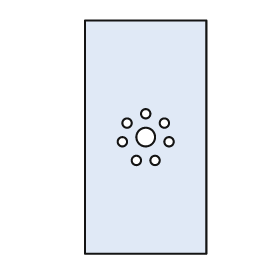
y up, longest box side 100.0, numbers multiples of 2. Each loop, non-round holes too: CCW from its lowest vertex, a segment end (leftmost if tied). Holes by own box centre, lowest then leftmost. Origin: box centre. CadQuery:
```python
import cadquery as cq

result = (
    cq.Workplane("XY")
    .moveTo(-26.0, -50.0)
    .lineTo(26.0, -50.0)
    .lineTo(26.0, 50.0)
    .lineTo(-26.0, 50.0)
    .close()
    .moveTo(-4.0, -10.0)
    .circle(2.0)
    .moveTo(4.0, -10.0)
    .circle(2.0)
    .moveTo(-10.0, -2.0)
    .circle(2.0)
    .moveTo(10.0, -2.0)
    .circle(2.0)
    .moveTo(0.0, 0.0)
    .circle(4.0)
    .moveTo(-8.0, 6.0)
    .circle(2.0)
    .moveTo(8.0, 6.0)
    .circle(2.0)
    .moveTo(0.0, 10.0)
    .circle(2.0)
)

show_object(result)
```